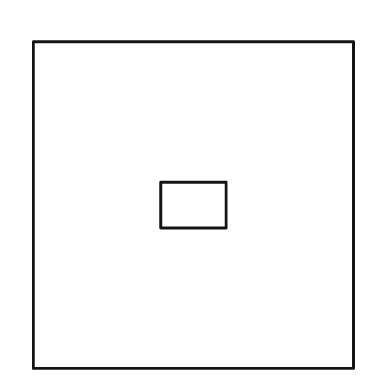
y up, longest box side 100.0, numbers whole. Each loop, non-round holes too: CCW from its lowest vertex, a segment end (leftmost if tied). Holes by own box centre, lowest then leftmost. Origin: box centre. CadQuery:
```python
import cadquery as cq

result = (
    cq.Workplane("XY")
    .moveTo(-49.0, -50.0)
    .lineTo(49.0, -50.0)
    .lineTo(49.0, 50.0)
    .lineTo(-49.0, 50.0)
    .close()
    .moveTo(-10.0, -7.0)
    .lineTo(10.0, -7.0)
    .lineTo(10.0, 7.0)
    .lineTo(-10.0, 7.0)
    .close()
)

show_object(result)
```